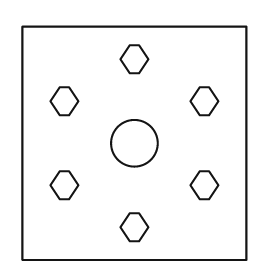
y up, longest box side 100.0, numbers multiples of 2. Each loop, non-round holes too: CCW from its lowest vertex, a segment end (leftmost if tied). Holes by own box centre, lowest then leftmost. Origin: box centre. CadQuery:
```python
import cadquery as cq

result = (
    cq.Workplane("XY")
    .moveTo(-48.0, -50.0)
    .lineTo(48.0, -50.0)
    .lineTo(48.0, 50.0)
    .lineTo(-48.0, 50.0)
    .close()
    .moveTo(-2.0, -42.0)
    .lineTo(2.0, -42.0)
    .lineTo(6.0, -36.0)
    .lineTo(2.0, -30.0)
    .lineTo(-2.0, -30.0)
    .lineTo(-6.0, -36.0)
    .close()
    .moveTo(-32.0, -24.0)
    .lineTo(-28.0, -24.0)
    .lineTo(-24.0, -18.0)
    .lineTo(-28.0, -12.0)
    .lineTo(-32.0, -12.0)
    .lineTo(-36.0, -18.0)
    .close()
    .moveTo(28.0, -24.0)
    .lineTo(32.0, -24.0)
    .lineTo(36.0, -18.0)
    .lineTo(32.0, -12.0)
    .lineTo(28.0, -12.0)
    .lineTo(24.0, -18.0)
    .close()
    .moveTo(0.0, 0.0)
    .circle(10.0)
    .moveTo(-32.0, 12.0)
    .lineTo(-28.0, 12.0)
    .lineTo(-24.0, 18.0)
    .lineTo(-28.0, 24.0)
    .lineTo(-32.0, 24.0)
    .lineTo(-36.0, 18.0)
    .close()
    .moveTo(28.0, 12.0)
    .lineTo(32.0, 12.0)
    .lineTo(36.0, 18.0)
    .lineTo(32.0, 24.0)
    .lineTo(28.0, 24.0)
    .lineTo(24.0, 18.0)
    .close()
    .moveTo(-2.0, 30.0)
    .lineTo(2.0, 30.0)
    .lineTo(6.0, 36.0)
    .lineTo(2.0, 42.0)
    .lineTo(-2.0, 42.0)
    .lineTo(-6.0, 36.0)
    .close()
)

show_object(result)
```